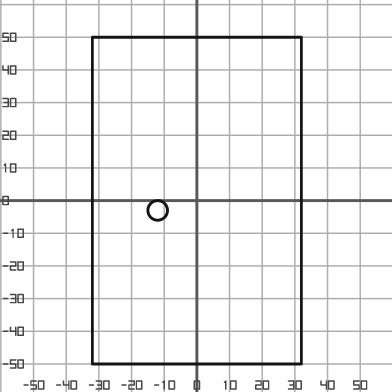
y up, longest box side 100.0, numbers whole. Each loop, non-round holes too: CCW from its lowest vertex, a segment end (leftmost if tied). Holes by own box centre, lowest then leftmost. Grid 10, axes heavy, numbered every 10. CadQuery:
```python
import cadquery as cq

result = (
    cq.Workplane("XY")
    .moveTo(-32.0, -50.0)
    .lineTo(32.0, -50.0)
    .lineTo(32.0, 50.0)
    .lineTo(-32.0, 50.0)
    .close()
    .moveTo(-12.0, -3.0)
    .circle(3.0)
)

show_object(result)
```